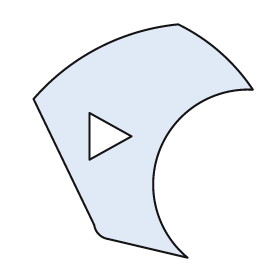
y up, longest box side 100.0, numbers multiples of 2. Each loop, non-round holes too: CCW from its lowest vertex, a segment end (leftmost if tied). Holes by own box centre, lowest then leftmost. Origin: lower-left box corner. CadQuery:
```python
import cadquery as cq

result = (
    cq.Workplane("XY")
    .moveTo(66.0, 0.0)
    .threePointArc((54.0, 46.0), (94.0, 72.0))
    .threePointArc((80.0, 88.0), (62.0, 100.0))
    .threePointArc((28.0, 90.0), (0.0, 68.0))
    .lineTo(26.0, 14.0)
    .threePointArc((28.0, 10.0), (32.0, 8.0))
    .close()
    .moveTo(24.0, 42.0)
    .lineTo(42.0, 52.0)
    .lineTo(24.0, 62.0)
    .close()
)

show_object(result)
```